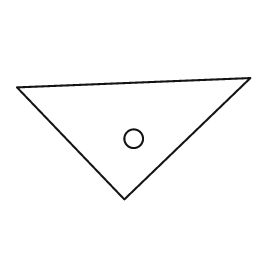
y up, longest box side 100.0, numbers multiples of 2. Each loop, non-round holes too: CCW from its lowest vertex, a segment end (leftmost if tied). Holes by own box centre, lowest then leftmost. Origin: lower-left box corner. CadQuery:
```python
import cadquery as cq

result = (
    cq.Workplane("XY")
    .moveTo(46.0, 0.0)
    .lineTo(100.0, 52.0)
    .lineTo(0.0, 48.0)
    .close()
    .moveTo(50.0, 26.0)
    .circle(4.0)
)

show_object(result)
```